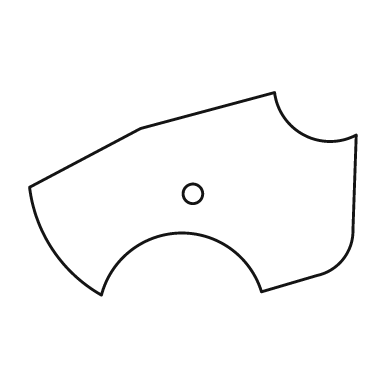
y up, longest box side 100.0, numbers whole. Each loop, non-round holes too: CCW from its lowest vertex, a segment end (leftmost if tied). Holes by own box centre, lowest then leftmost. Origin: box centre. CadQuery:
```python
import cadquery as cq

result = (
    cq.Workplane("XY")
    .moveTo(-28.0, -31.0)
    .threePointArc((-4.0, -12.0), (21.0, -30.0))
    .lineTo(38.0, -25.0)
    .threePointArc((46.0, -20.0), (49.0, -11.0))
    .lineTo(50.0, 18.0)
    .threePointArc((34.0, 18.0), (25.0, 31.0))
    .lineTo(-16.0, 20.0)
    .lineTo(-50.0, 2.0)
    .threePointArc((-43.0, -17.0), (-28.0, -31.0))
    .close()
    .moveTo(0.0, 0.0)
    .circle(3.0)
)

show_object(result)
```